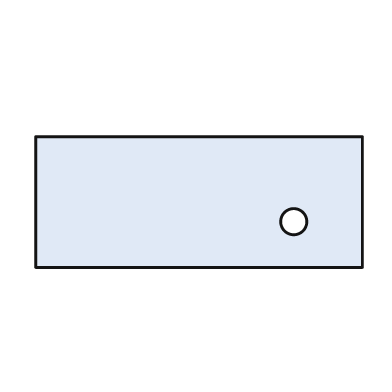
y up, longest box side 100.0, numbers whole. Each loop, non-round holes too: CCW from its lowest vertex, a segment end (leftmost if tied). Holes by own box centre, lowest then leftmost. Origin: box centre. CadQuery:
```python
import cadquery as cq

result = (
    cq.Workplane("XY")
    .moveTo(-50.0, -20.0)
    .lineTo(50.0, -20.0)
    .lineTo(50.0, 20.0)
    .lineTo(-50.0, 20.0)
    .close()
    .moveTo(29.0, -6.0)
    .circle(4.0)
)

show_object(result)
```